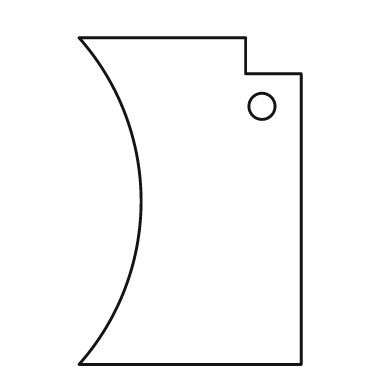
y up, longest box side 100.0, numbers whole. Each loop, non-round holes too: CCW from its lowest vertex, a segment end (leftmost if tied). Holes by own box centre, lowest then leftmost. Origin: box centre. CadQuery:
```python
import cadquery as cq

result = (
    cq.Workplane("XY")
    .moveTo(-34.0, -50.0)
    .lineTo(34.0, -50.0)
    .lineTo(34.0, 39.0)
    .lineTo(17.0, 39.0)
    .lineTo(17.0, 50.0)
    .lineTo(-34.0, 50.0)
    .threePointArc((-15.0, 0.0), (-34.0, -50.0))
    .close()
    .moveTo(22.0, 29.0)
    .circle(4.0)
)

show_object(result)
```